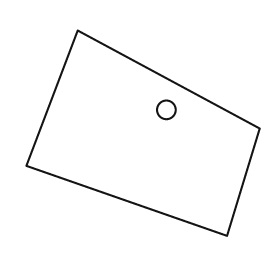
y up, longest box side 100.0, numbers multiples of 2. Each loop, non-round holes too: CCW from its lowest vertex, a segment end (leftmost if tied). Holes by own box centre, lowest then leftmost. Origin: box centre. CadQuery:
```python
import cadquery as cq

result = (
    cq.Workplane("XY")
    .moveTo(36.0, -44.0)
    .lineTo(50.0, 2.0)
    .lineTo(-28.0, 44.0)
    .lineTo(-50.0, -14.0)
    .close()
    .moveTo(10.0, 10.0)
    .circle(4.0)
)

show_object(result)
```